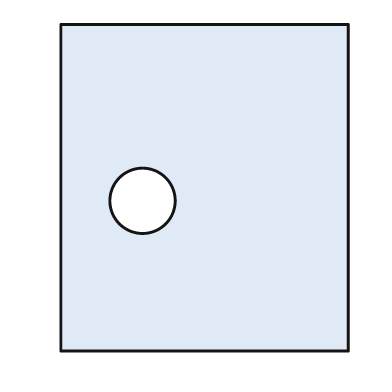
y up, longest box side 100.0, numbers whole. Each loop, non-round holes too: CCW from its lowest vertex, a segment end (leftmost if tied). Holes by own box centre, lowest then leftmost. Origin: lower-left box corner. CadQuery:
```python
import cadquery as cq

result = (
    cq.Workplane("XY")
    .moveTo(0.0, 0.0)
    .lineTo(88.0, 0.0)
    .lineTo(88.0, 100.0)
    .lineTo(0.0, 100.0)
    .close()
    .moveTo(25.0, 46.0)
    .circle(10.0)
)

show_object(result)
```